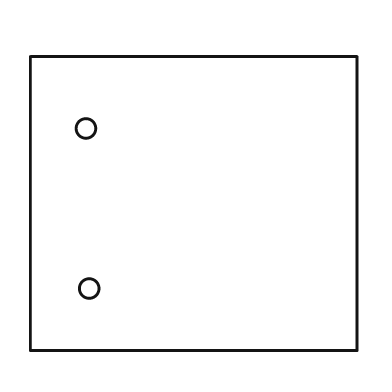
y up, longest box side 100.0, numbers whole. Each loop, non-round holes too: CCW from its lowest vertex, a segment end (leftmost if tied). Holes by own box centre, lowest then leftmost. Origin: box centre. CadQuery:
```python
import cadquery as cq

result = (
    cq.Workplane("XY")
    .moveTo(-50.0, -45.0)
    .lineTo(50.0, -45.0)
    .lineTo(50.0, 45.0)
    .lineTo(-50.0, 45.0)
    .close()
    .moveTo(-32.0, -26.0)
    .circle(3.0)
    .moveTo(-33.0, 23.0)
    .circle(3.0)
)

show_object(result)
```